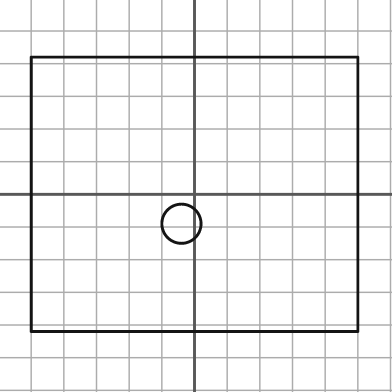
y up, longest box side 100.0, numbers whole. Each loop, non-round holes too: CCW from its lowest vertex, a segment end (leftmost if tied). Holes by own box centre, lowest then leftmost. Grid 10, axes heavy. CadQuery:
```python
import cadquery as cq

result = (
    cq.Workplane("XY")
    .moveTo(-50.0, -42.0)
    .lineTo(50.0, -42.0)
    .lineTo(50.0, 42.0)
    .lineTo(-50.0, 42.0)
    .close()
    .moveTo(-4.0, -9.0)
    .circle(6.0)
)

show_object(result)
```